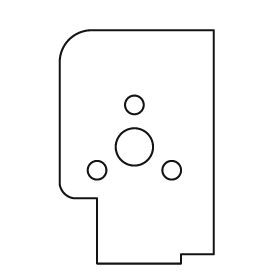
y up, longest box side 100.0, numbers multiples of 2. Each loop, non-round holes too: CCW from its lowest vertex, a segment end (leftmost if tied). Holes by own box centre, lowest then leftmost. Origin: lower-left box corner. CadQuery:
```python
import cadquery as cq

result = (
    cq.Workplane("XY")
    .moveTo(16.0, 0.0)
    .lineTo(52.0, 0.0)
    .lineTo(52.0, 4.0)
    .lineTo(66.0, 4.0)
    .lineTo(66.0, 100.0)
    .lineTo(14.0, 100.0)
    .threePointArc((4.0, 96.0), (0.0, 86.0))
    .lineTo(0.0, 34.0)
    .threePointArc((2.0, 30.0), (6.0, 28.0))
    .lineTo(16.0, 28.0)
    .close()
    .moveTo(16.0, 40.0)
    .circle(4.0)
    .moveTo(48.0, 40.0)
    .circle(4.0)
    .moveTo(32.0, 50.0)
    .circle(8.0)
    .moveTo(32.0, 68.0)
    .circle(4.0)
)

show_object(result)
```